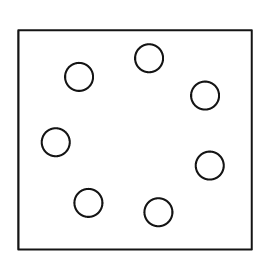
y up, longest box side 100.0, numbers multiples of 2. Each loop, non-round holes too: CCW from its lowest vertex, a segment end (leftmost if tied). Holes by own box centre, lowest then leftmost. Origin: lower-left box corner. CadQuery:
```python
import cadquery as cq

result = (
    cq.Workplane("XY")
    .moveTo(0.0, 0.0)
    .lineTo(100.0, 0.0)
    .lineTo(100.0, 94.0)
    .lineTo(0.0, 94.0)
    .close()
    .moveTo(60.0, 16.0)
    .circle(6.0)
    .moveTo(30.0, 20.0)
    .circle(6.0)
    .moveTo(82.0, 36.0)
    .circle(6.0)
    .moveTo(16.0, 46.0)
    .circle(6.0)
    .moveTo(80.0, 66.0)
    .circle(6.0)
    .moveTo(26.0, 74.0)
    .circle(6.0)
    .moveTo(56.0, 82.0)
    .circle(6.0)
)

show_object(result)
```